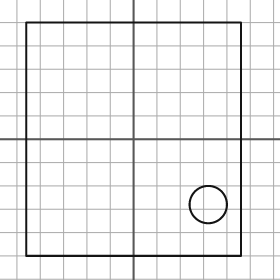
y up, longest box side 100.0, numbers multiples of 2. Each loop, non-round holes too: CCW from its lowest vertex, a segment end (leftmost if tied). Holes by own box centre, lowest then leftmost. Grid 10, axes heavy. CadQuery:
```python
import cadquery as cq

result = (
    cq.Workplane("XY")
    .moveTo(-46.0, -50.0)
    .lineTo(46.0, -50.0)
    .lineTo(46.0, 50.0)
    .lineTo(-46.0, 50.0)
    .close()
    .moveTo(32.0, -28.0)
    .circle(8.0)
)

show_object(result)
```